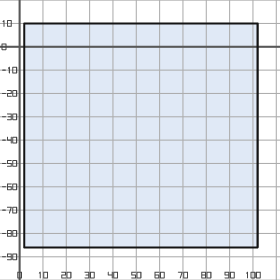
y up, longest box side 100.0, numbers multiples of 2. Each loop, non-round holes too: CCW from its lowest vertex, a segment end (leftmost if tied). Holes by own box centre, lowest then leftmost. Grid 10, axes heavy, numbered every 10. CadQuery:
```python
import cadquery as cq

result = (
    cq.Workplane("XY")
    .moveTo(2.0, -86.0)
    .lineTo(102.0, -86.0)
    .lineTo(102.0, 10.0)
    .lineTo(2.0, 10.0)
    .close()
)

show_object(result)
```